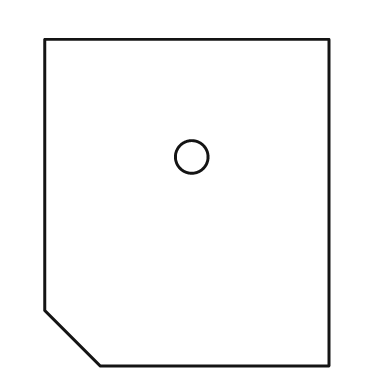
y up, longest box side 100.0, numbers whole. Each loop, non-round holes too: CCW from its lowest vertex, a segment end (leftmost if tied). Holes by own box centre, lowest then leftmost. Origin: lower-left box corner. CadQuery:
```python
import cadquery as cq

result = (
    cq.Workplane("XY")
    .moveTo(17.0, 0.0)
    .lineTo(87.0, 0.0)
    .lineTo(87.0, 100.0)
    .lineTo(0.0, 100.0)
    .lineTo(0.0, 17.0)
    .close()
    .moveTo(45.0, 64.0)
    .circle(5.0)
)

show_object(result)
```